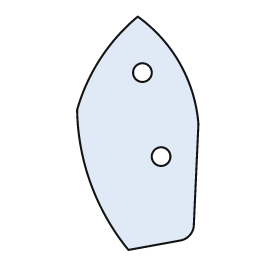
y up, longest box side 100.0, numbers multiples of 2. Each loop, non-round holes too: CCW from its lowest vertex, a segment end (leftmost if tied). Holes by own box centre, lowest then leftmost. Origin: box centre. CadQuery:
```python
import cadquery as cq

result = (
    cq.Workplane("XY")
    .moveTo(-4.0, -50.0)
    .lineTo(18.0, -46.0)
    .threePointArc((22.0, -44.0), (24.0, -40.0))
    .lineTo(26.0, 4.0)
    .threePointArc((18.0, 30.0), (0.0, 50.0))
    .threePointArc((-16.0, 32.0), (-26.0, 10.0))
    .threePointArc((-20.0, -22.0), (-4.0, -50.0))
    .close()
    .moveTo(10.0, -10.0)
    .circle(4.0)
    .moveTo(2.0, 26.0)
    .circle(4.0)
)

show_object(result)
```